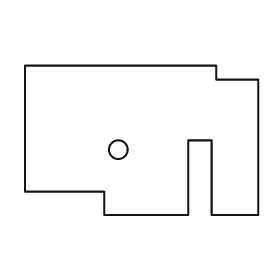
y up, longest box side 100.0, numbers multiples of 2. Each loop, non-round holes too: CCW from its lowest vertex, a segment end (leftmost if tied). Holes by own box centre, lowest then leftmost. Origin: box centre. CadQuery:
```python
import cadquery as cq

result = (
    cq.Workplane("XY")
    .moveTo(-16.0, -32.0)
    .lineTo(20.0, -32.0)
    .lineTo(20.0, 0.0)
    .lineTo(30.0, 0.0)
    .lineTo(30.0, -32.0)
    .lineTo(50.0, -32.0)
    .lineTo(50.0, 26.0)
    .lineTo(32.0, 26.0)
    .lineTo(32.0, 32.0)
    .lineTo(-50.0, 32.0)
    .lineTo(-50.0, -22.0)
    .lineTo(-16.0, -22.0)
    .close()
    .moveTo(-10.0, -4.0)
    .circle(4.0)
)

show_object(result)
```